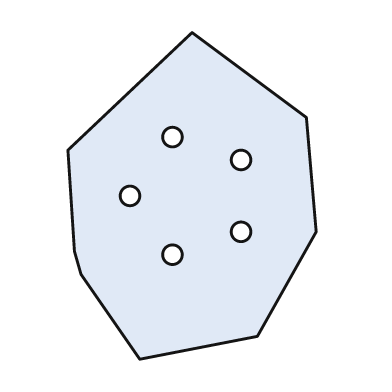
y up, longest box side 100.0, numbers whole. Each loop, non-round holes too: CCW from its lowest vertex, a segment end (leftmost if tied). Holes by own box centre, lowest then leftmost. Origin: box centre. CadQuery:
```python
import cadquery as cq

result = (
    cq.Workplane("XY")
    .moveTo(-16.0, -50.0)
    .lineTo(20.0, -43.0)
    .lineTo(38.0, -11.0)
    .lineTo(35.0, 24.0)
    .lineTo(0.0, 50.0)
    .lineTo(-38.0, 14.0)
    .lineTo(-36.0, -17.0)
    .lineTo(-34.0, -24.0)
    .close()
    .moveTo(-6.0, -18.0)
    .circle(3.0)
    .moveTo(15.0, -11.0)
    .circle(3.0)
    .moveTo(-19.0, 0.0)
    .circle(3.0)
    .moveTo(15.0, 11.0)
    .circle(3.0)
    .moveTo(-6.0, 18.0)
    .circle(3.0)
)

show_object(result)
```